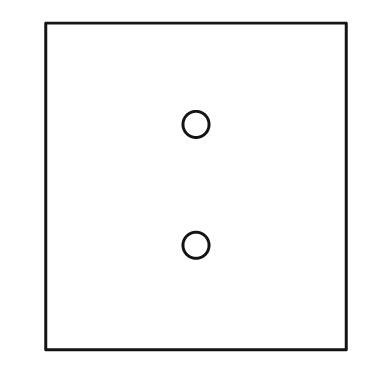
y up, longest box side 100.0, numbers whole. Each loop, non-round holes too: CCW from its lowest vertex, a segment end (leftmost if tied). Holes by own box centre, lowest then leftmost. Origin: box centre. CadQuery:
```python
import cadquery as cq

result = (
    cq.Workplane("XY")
    .moveTo(-46.0, -50.0)
    .lineTo(46.0, -50.0)
    .lineTo(46.0, 50.0)
    .lineTo(-46.0, 50.0)
    .close()
    .moveTo(0.0, -18.0)
    .circle(4.0)
    .moveTo(0.0, 19.0)
    .circle(4.0)
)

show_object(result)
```